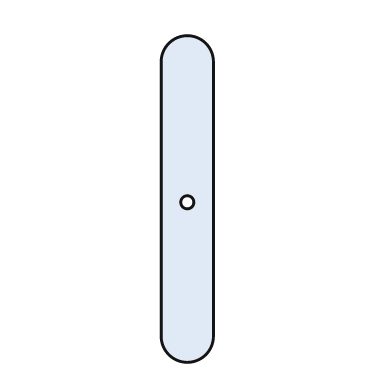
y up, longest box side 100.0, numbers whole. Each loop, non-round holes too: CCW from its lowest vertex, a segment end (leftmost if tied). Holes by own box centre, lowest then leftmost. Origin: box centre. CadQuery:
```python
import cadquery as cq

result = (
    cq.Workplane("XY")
    .moveTo(-8.0, -42.0)
    .threePointArc((0.0, -50.0), (8.0, -42.0))
    .lineTo(8.0, 42.0)
    .threePointArc((0.0, 50.0), (-8.0, 42.0))
    .close()
    .moveTo(0.0, -1.0)
    .circle(2.0)
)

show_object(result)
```